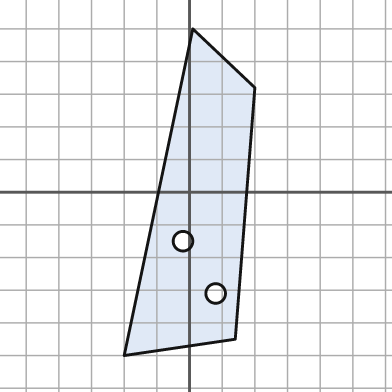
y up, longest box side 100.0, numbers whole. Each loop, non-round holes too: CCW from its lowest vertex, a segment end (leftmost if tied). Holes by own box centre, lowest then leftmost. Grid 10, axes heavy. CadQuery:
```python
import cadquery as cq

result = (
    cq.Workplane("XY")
    .moveTo(-20.0, -50.0)
    .lineTo(14.0, -45.0)
    .lineTo(20.0, 32.0)
    .lineTo(1.0, 50.0)
    .close()
    .moveTo(8.0, -31.0)
    .circle(3.0)
    .moveTo(-2.0, -15.0)
    .circle(3.0)
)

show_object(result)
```